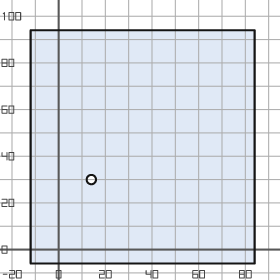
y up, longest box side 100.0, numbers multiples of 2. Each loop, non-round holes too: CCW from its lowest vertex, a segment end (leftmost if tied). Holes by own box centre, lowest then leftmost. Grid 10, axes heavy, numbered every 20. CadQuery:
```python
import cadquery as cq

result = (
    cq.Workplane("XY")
    .moveTo(-12.0, -6.0)
    .lineTo(84.0, -6.0)
    .lineTo(84.0, 94.0)
    .lineTo(-12.0, 94.0)
    .close()
    .moveTo(14.0, 30.0)
    .circle(2.0)
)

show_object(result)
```